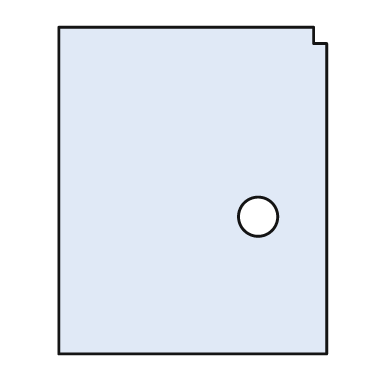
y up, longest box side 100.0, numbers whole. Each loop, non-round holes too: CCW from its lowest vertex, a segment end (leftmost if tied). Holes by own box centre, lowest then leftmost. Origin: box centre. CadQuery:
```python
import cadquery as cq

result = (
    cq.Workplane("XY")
    .moveTo(-41.0, -50.0)
    .lineTo(41.0, -50.0)
    .lineTo(41.0, 45.0)
    .lineTo(37.0, 45.0)
    .lineTo(37.0, 50.0)
    .lineTo(-41.0, 50.0)
    .close()
    .moveTo(20.0, -8.0)
    .circle(6.0)
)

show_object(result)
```